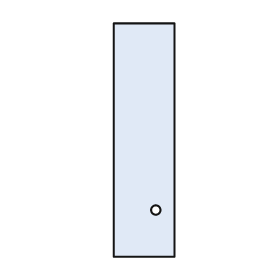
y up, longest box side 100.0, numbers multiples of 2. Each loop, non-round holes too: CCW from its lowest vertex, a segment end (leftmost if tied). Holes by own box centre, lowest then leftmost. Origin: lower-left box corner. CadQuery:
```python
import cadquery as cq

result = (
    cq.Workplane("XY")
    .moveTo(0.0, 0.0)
    .lineTo(26.0, 0.0)
    .lineTo(26.0, 100.0)
    .lineTo(0.0, 100.0)
    .close()
    .moveTo(18.0, 20.0)
    .circle(2.0)
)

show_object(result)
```